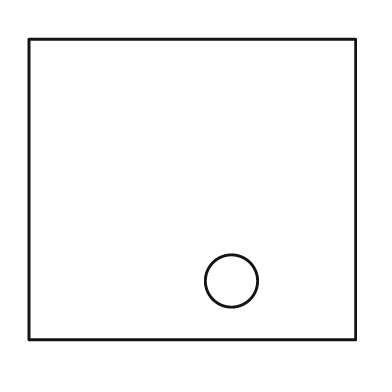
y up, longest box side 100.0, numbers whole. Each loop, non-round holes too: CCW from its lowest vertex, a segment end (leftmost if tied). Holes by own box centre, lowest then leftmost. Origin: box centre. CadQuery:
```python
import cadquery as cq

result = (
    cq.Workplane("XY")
    .moveTo(-50.0, -46.0)
    .lineTo(50.0, -46.0)
    .lineTo(50.0, 46.0)
    .lineTo(-50.0, 46.0)
    .close()
    .moveTo(12.0, -28.0)
    .circle(8.0)
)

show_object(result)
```